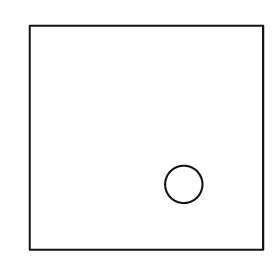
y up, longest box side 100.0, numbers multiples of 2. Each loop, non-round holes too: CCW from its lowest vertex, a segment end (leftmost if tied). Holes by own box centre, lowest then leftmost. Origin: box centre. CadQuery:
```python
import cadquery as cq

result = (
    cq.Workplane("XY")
    .moveTo(-50.0, -48.0)
    .lineTo(50.0, -48.0)
    .lineTo(50.0, 48.0)
    .lineTo(-50.0, 48.0)
    .close()
    .moveTo(16.0, -20.0)
    .circle(8.0)
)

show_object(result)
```